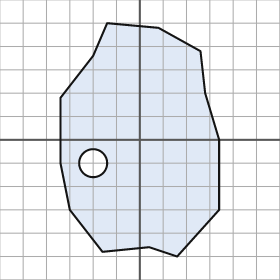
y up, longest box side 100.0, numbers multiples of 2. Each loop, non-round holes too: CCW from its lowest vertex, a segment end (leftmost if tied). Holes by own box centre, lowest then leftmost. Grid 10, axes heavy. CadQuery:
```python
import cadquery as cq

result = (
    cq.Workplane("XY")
    .moveTo(16.0, -50.0)
    .lineTo(34.0, -30.0)
    .lineTo(34.0, 0.0)
    .lineTo(28.0, 20.0)
    .lineTo(26.0, 38.0)
    .lineTo(8.0, 48.0)
    .lineTo(-14.0, 50.0)
    .lineTo(-20.0, 36.0)
    .lineTo(-34.0, 18.0)
    .lineTo(-34.0, -10.0)
    .lineTo(-30.0, -30.0)
    .lineTo(-16.0, -48.0)
    .lineTo(4.0, -46.0)
    .close()
    .moveTo(-20.0, -10.0)
    .circle(6.0)
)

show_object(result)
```